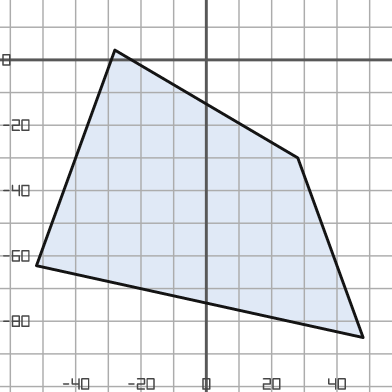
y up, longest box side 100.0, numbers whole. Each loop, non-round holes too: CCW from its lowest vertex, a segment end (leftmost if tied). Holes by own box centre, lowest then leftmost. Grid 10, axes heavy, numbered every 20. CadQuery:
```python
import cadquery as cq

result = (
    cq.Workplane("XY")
    .moveTo(48.0, -85.0)
    .lineTo(28.0, -30.0)
    .lineTo(-28.0, 3.0)
    .lineTo(-52.0, -63.0)
    .close()
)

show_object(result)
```